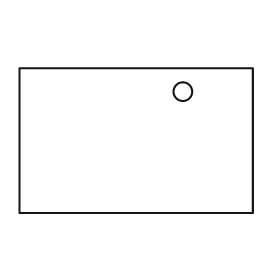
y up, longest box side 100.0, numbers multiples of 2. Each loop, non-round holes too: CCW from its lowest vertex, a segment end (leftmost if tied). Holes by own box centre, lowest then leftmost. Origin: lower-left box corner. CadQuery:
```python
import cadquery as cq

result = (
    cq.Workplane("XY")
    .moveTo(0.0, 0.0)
    .lineTo(100.0, 0.0)
    .lineTo(100.0, 62.0)
    .lineTo(0.0, 62.0)
    .close()
    .moveTo(70.0, 52.0)
    .circle(4.0)
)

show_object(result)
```